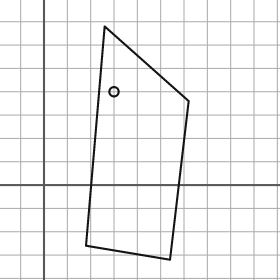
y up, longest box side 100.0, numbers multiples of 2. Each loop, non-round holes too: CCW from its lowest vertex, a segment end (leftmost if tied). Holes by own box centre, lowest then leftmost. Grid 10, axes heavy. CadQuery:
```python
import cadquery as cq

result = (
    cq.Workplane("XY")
    .moveTo(54.0, -32.0)
    .lineTo(62.0, 36.0)
    .lineTo(26.0, 68.0)
    .lineTo(18.0, -26.0)
    .close()
    .moveTo(30.0, 40.0)
    .circle(2.0)
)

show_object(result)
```